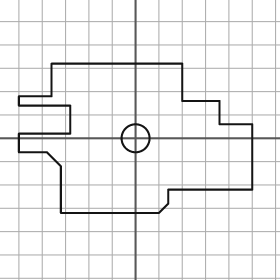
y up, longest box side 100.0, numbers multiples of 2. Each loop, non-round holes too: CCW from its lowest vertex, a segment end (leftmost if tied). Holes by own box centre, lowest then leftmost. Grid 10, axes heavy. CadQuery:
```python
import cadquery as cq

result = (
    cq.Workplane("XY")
    .moveTo(-32.0, -32.0)
    .lineTo(10.0, -32.0)
    .lineTo(14.0, -28.0)
    .lineTo(14.0, -22.0)
    .lineTo(50.0, -22.0)
    .lineTo(50.0, 6.0)
    .lineTo(36.0, 6.0)
    .lineTo(36.0, 16.0)
    .lineTo(20.0, 16.0)
    .lineTo(20.0, 32.0)
    .lineTo(-36.0, 32.0)
    .lineTo(-36.0, 18.0)
    .lineTo(-50.0, 18.0)
    .lineTo(-50.0, 14.0)
    .lineTo(-28.0, 14.0)
    .lineTo(-28.0, 2.0)
    .lineTo(-50.0, 2.0)
    .lineTo(-50.0, -6.0)
    .lineTo(-38.0, -6.0)
    .lineTo(-32.0, -12.0)
    .close()
    .moveTo(0.0, 0.0)
    .circle(6.0)
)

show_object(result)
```